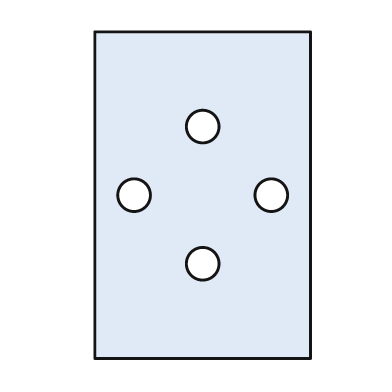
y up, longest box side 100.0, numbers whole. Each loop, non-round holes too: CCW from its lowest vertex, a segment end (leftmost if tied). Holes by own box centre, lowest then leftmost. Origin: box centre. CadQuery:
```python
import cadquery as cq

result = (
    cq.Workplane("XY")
    .moveTo(-33.0, -50.0)
    .lineTo(33.0, -50.0)
    .lineTo(33.0, 50.0)
    .lineTo(-33.0, 50.0)
    .close()
    .moveTo(0.0, -21.0)
    .circle(5.0)
    .moveTo(-21.0, 0.0)
    .circle(5.0)
    .moveTo(21.0, 0.0)
    .circle(5.0)
    .moveTo(0.0, 21.0)
    .circle(5.0)
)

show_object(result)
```